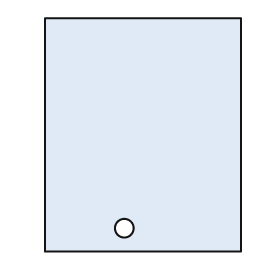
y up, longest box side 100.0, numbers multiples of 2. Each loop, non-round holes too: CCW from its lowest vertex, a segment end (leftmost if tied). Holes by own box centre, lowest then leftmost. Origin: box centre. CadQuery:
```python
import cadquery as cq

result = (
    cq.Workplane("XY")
    .moveTo(-42.0, -50.0)
    .lineTo(42.0, -50.0)
    .lineTo(42.0, 50.0)
    .lineTo(-42.0, 50.0)
    .close()
    .moveTo(-8.0, -40.0)
    .circle(4.0)
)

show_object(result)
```